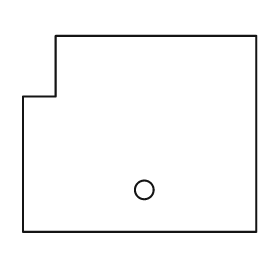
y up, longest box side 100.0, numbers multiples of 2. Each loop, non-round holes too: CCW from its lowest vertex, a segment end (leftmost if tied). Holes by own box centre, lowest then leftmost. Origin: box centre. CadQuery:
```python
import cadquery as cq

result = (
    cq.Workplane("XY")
    .moveTo(-50.0, -42.0)
    .lineTo(50.0, -42.0)
    .lineTo(50.0, 42.0)
    .lineTo(-36.0, 42.0)
    .lineTo(-36.0, 16.0)
    .lineTo(-50.0, 16.0)
    .close()
    .moveTo(2.0, -24.0)
    .circle(4.0)
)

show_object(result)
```